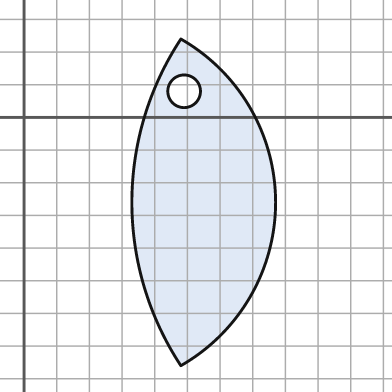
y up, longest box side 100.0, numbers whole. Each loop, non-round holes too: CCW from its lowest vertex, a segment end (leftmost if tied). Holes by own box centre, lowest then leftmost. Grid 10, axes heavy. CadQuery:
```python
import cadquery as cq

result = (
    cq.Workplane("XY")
    .moveTo(48.0, -76.0)
    .threePointArc((77.0, -26.0), (48.0, 24.0))
    .threePointArc((33.0, -26.0), (48.0, -76.0))
    .close()
    .moveTo(49.0, 8.0)
    .circle(5.0)
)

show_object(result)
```